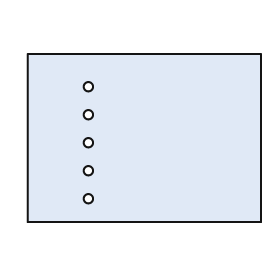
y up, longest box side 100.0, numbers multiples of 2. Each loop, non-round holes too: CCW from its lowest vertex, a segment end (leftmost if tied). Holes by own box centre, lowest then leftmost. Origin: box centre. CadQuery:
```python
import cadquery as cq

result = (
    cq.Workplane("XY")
    .moveTo(-50.0, -36.0)
    .lineTo(50.0, -36.0)
    .lineTo(50.0, 36.0)
    .lineTo(-50.0, 36.0)
    .close()
    .moveTo(-24.0, -26.0)
    .circle(2.0)
    .moveTo(-24.0, -14.0)
    .circle(2.0)
    .moveTo(-24.0, -2.0)
    .circle(2.0)
    .moveTo(-24.0, 10.0)
    .circle(2.0)
    .moveTo(-24.0, 22.0)
    .circle(2.0)
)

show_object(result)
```